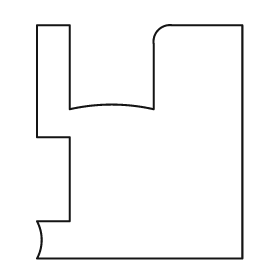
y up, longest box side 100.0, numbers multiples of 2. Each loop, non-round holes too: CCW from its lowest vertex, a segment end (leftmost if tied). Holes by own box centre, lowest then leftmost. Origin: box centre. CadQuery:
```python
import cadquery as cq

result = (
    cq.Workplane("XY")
    .moveTo(-44.0, -50.0)
    .lineTo(44.0, -50.0)
    .lineTo(44.0, 50.0)
    .lineTo(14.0, 50.0)
    .threePointArc((8.0, 48.0), (6.0, 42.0))
    .lineTo(6.0, 14.0)
    .threePointArc((-12.0, 16.0), (-30.0, 14.0))
    .lineTo(-30.0, 50.0)
    .lineTo(-44.0, 50.0)
    .lineTo(-44.0, 2.0)
    .lineTo(-30.0, 2.0)
    .lineTo(-30.0, -34.0)
    .lineTo(-44.0, -34.0)
    .threePointArc((-42.0, -42.0), (-44.0, -50.0))
    .close()
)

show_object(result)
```